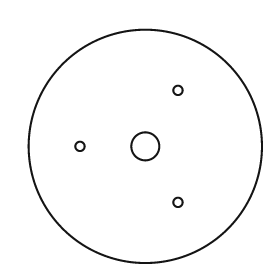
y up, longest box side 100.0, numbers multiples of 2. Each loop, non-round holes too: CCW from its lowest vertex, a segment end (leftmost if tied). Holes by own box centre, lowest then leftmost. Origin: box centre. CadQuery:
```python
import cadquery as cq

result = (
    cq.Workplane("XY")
    .moveTo(0.0, 0.0)
    .circle(50.0)
    .moveTo(14.0, -24.0)
    .circle(2.0)
    .moveTo(-28.0, 0.0)
    .circle(2.0)
    .moveTo(0.0, 0.0)
    .circle(6.0)
    .moveTo(14.0, 24.0)
    .circle(2.0)
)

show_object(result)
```